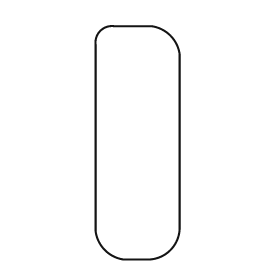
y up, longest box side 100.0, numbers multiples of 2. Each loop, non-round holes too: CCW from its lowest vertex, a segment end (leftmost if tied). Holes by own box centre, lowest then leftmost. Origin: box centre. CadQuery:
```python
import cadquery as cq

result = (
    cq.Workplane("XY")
    .moveTo(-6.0, -50.0)
    .lineTo(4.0, -50.0)
    .threePointArc((14.0, -46.0), (18.0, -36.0))
    .lineTo(18.0, 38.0)
    .threePointArc((14.0, 46.0), (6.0, 50.0))
    .lineTo(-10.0, 50.0)
    .threePointArc((-16.0, 48.0), (-18.0, 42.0))
    .lineTo(-18.0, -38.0)
    .threePointArc((-14.0, -46.0), (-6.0, -50.0))
    .close()
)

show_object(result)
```